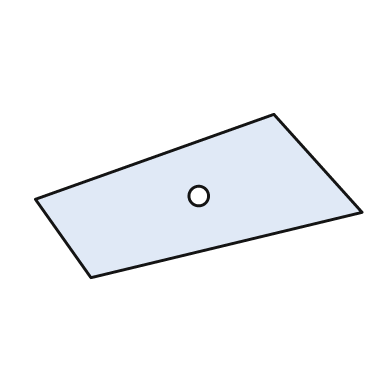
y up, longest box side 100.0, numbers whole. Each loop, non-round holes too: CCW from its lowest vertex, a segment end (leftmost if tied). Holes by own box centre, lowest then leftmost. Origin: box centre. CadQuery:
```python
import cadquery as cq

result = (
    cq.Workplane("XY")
    .moveTo(-33.0, -25.0)
    .lineTo(50.0, -5.0)
    .lineTo(23.0, 25.0)
    .lineTo(-50.0, -1.0)
    .close()
    .moveTo(0.0, 0.0)
    .circle(3.0)
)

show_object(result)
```